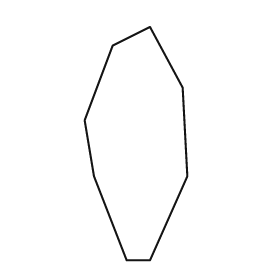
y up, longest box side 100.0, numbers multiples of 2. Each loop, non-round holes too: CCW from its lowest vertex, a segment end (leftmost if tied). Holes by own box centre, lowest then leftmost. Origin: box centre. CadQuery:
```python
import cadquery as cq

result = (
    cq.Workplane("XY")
    .moveTo(-4.0, -50.0)
    .lineTo(6.0, -50.0)
    .lineTo(22.0, -14.0)
    .lineTo(20.0, 24.0)
    .lineTo(6.0, 50.0)
    .lineTo(-10.0, 42.0)
    .lineTo(-22.0, 10.0)
    .lineTo(-18.0, -14.0)
    .close()
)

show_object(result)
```